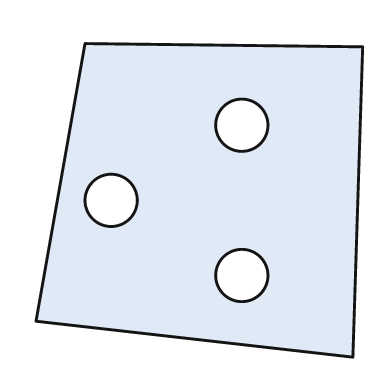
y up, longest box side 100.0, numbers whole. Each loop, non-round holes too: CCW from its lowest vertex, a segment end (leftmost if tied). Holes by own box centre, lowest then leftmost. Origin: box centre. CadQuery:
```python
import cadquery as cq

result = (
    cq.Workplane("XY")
    .moveTo(47.0, -48.0)
    .lineTo(50.0, 47.0)
    .lineTo(-35.0, 48.0)
    .lineTo(-50.0, -37.0)
    .close()
    .moveTo(13.0, -23.0)
    .circle(8.0)
    .moveTo(-27.0, 0.0)
    .circle(8.0)
    .moveTo(13.0, 23.0)
    .circle(8.0)
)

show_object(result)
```